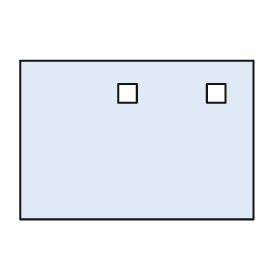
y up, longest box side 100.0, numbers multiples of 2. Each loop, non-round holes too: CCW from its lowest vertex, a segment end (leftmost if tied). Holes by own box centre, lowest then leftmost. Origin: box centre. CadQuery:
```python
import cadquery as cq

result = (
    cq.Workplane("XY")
    .moveTo(-50.0, -34.0)
    .lineTo(50.0, -34.0)
    .lineTo(50.0, 34.0)
    .lineTo(-50.0, 34.0)
    .close()
    .moveTo(-8.0, 16.0)
    .lineTo(0.0, 16.0)
    .lineTo(0.0, 24.0)
    .lineTo(-8.0, 24.0)
    .close()
    .moveTo(30.0, 16.0)
    .lineTo(38.0, 16.0)
    .lineTo(38.0, 24.0)
    .lineTo(30.0, 24.0)
    .close()
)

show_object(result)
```